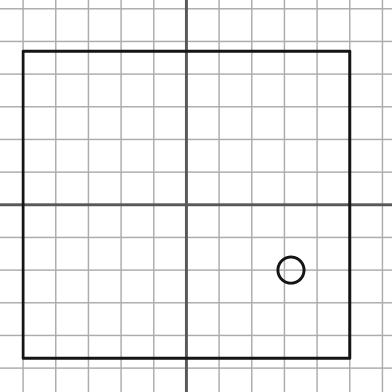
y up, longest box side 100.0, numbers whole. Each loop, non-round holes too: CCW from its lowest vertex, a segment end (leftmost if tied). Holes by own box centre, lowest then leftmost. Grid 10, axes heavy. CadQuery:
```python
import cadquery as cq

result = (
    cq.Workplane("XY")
    .moveTo(-50.0, -47.0)
    .lineTo(50.0, -47.0)
    .lineTo(50.0, 47.0)
    .lineTo(-50.0, 47.0)
    .close()
    .moveTo(32.0, -20.0)
    .circle(4.0)
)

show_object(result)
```